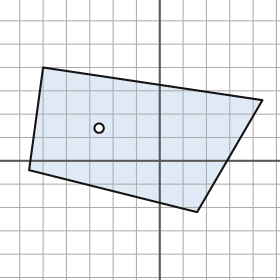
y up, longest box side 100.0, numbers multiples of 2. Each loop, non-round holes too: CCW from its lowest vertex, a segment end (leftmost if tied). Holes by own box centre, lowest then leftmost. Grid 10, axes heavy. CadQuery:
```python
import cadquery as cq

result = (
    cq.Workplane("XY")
    .moveTo(16.0, -22.0)
    .lineTo(44.0, 26.0)
    .lineTo(-50.0, 40.0)
    .lineTo(-56.0, -4.0)
    .close()
    .moveTo(-26.0, 14.0)
    .circle(2.0)
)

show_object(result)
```